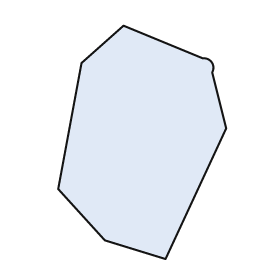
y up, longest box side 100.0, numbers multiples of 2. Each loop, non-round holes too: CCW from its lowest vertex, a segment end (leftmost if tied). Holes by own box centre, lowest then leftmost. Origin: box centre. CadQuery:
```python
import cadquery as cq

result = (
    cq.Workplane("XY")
    .moveTo(10.0, -50.0)
    .lineTo(36.0, 6.0)
    .lineTo(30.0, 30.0)
    .threePointArc((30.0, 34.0), (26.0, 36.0))
    .lineTo(-8.0, 50.0)
    .lineTo(-26.0, 34.0)
    .lineTo(-36.0, -20.0)
    .lineTo(-16.0, -42.0)
    .close()
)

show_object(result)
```